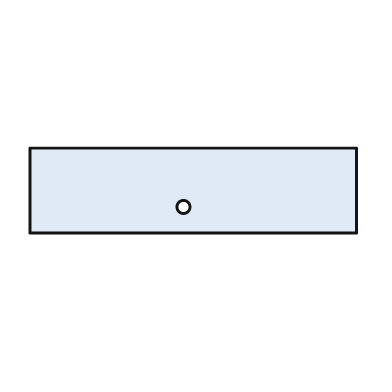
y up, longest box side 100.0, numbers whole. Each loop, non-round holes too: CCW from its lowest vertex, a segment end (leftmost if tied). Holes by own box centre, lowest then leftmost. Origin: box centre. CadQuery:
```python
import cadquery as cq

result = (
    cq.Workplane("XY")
    .moveTo(-50.0, -13.0)
    .lineTo(50.0, -13.0)
    .lineTo(50.0, 13.0)
    .lineTo(-50.0, 13.0)
    .close()
    .moveTo(-3.0, -5.0)
    .circle(2.0)
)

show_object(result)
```